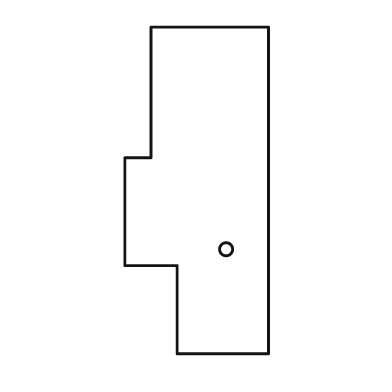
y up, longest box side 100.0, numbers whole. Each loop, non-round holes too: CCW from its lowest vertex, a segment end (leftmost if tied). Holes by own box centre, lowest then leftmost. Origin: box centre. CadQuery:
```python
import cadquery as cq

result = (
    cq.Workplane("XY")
    .moveTo(-6.0, -50.0)
    .lineTo(22.0, -50.0)
    .lineTo(22.0, 50.0)
    .lineTo(-14.0, 50.0)
    .lineTo(-14.0, 10.0)
    .lineTo(-22.0, 10.0)
    .lineTo(-22.0, -23.0)
    .lineTo(-6.0, -23.0)
    .close()
    .moveTo(9.0, -18.0)
    .circle(2.0)
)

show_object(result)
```